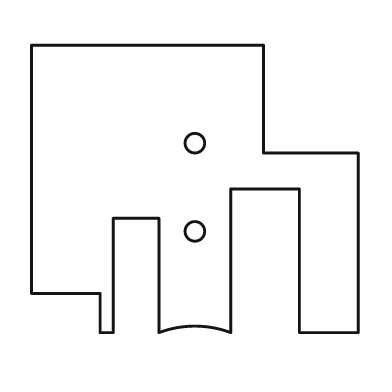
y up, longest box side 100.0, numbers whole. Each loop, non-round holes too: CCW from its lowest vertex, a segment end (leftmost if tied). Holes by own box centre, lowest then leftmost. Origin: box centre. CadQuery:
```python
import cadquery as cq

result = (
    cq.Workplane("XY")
    .moveTo(-29.0, -44.0)
    .lineTo(-25.0, -44.0)
    .lineTo(-25.0, -9.0)
    .lineTo(-11.0, -9.0)
    .lineTo(-11.0, -44.0)
    .threePointArc((0.0, -42.0), (11.0, -44.0))
    .lineTo(11.0, 0.0)
    .lineTo(32.0, 0.0)
    .lineTo(32.0, -44.0)
    .lineTo(50.0, -44.0)
    .lineTo(50.0, 11.0)
    .lineTo(21.0, 11.0)
    .lineTo(21.0, 44.0)
    .lineTo(-50.0, 44.0)
    .lineTo(-50.0, -32.0)
    .lineTo(-29.0, -32.0)
    .close()
    .moveTo(0.0, -13.0)
    .circle(3.0)
    .moveTo(0.0, 14.0)
    .circle(3.0)
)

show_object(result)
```